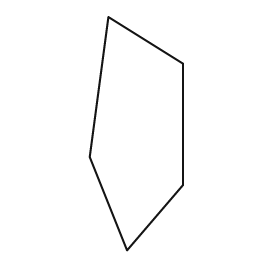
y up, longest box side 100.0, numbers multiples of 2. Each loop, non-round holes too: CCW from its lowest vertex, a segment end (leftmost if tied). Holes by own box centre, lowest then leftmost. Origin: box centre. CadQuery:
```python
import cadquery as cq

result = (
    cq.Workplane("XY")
    .moveTo(-4.0, -50.0)
    .lineTo(20.0, -22.0)
    .lineTo(20.0, 30.0)
    .lineTo(-12.0, 50.0)
    .lineTo(-20.0, -10.0)
    .close()
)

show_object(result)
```